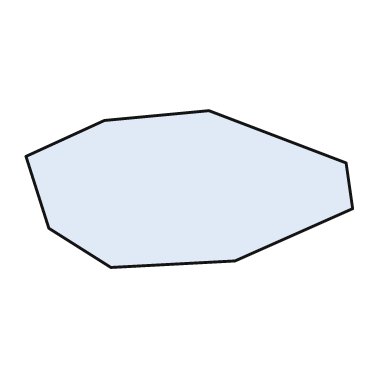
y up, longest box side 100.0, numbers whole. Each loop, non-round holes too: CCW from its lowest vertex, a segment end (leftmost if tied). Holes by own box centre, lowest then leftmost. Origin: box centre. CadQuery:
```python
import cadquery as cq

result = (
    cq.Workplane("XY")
    .moveTo(-24.0, -24.0)
    .lineTo(14.0, -22.0)
    .lineTo(50.0, -6.0)
    .lineTo(48.0, 8.0)
    .lineTo(6.0, 24.0)
    .lineTo(-26.0, 21.0)
    .lineTo(-50.0, 10.0)
    .lineTo(-43.0, -12.0)
    .close()
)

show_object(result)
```